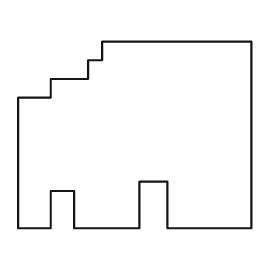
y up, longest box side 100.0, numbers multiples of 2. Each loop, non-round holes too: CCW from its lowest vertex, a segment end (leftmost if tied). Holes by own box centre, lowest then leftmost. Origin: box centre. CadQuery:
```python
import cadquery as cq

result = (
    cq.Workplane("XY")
    .moveTo(-50.0, -40.0)
    .lineTo(-36.0, -40.0)
    .lineTo(-36.0, -24.0)
    .lineTo(-26.0, -24.0)
    .lineTo(-26.0, -40.0)
    .lineTo(2.0, -40.0)
    .lineTo(2.0, -20.0)
    .lineTo(14.0, -20.0)
    .lineTo(14.0, -40.0)
    .lineTo(50.0, -40.0)
    .lineTo(50.0, 40.0)
    .lineTo(-14.0, 40.0)
    .lineTo(-14.0, 32.0)
    .lineTo(-20.0, 32.0)
    .lineTo(-20.0, 24.0)
    .lineTo(-36.0, 24.0)
    .lineTo(-36.0, 16.0)
    .lineTo(-50.0, 16.0)
    .close()
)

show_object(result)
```